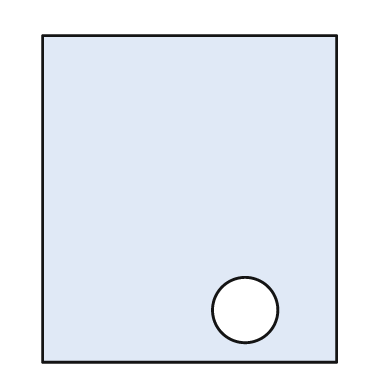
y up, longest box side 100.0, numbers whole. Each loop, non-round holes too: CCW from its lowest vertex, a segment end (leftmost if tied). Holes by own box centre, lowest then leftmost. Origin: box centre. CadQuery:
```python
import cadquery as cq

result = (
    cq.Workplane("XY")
    .moveTo(-45.0, -50.0)
    .lineTo(45.0, -50.0)
    .lineTo(45.0, 50.0)
    .lineTo(-45.0, 50.0)
    .close()
    .moveTo(17.0, -34.0)
    .circle(10.0)
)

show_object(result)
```